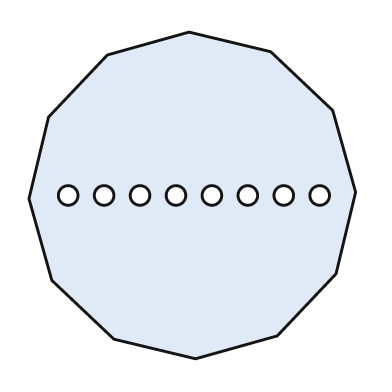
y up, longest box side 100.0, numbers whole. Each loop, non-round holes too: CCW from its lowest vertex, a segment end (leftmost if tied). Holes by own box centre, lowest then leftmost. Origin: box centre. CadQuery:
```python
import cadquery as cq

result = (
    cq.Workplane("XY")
    .moveTo(1.0, -50.0)
    .lineTo(26.0, -43.0)
    .lineTo(44.0, -24.0)
    .lineTo(50.0, 1.0)
    .lineTo(43.0, 26.0)
    .lineTo(24.0, 44.0)
    .lineTo(-1.0, 50.0)
    .lineTo(-26.0, 43.0)
    .lineTo(-44.0, 24.0)
    .lineTo(-50.0, -1.0)
    .lineTo(-43.0, -26.0)
    .lineTo(-24.0, -44.0)
    .close()
    .moveTo(-38.0, 0.0)
    .circle(3.0)
    .moveTo(-27.0, 0.0)
    .circle(3.0)
    .moveTo(-16.0, 0.0)
    .circle(3.0)
    .moveTo(-5.0, 0.0)
    .circle(3.0)
    .moveTo(6.0, 0.0)
    .circle(3.0)
    .moveTo(17.0, 0.0)
    .circle(3.0)
    .moveTo(28.0, 0.0)
    .circle(3.0)
    .moveTo(39.0, 0.0)
    .circle(3.0)
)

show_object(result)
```